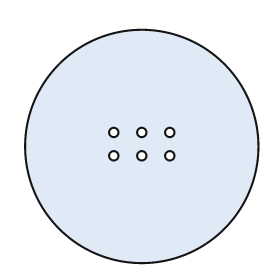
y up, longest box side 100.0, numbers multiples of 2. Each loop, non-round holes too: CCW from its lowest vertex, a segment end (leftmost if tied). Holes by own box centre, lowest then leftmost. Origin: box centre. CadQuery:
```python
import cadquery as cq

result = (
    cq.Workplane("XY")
    .moveTo(0.0, 0.0)
    .circle(50.0)
    .moveTo(-12.0, -4.0)
    .circle(2.0)
    .moveTo(0.0, -4.0)
    .circle(2.0)
    .moveTo(12.0, -4.0)
    .circle(2.0)
    .moveTo(-12.0, 6.0)
    .circle(2.0)
    .moveTo(0.0, 6.0)
    .circle(2.0)
    .moveTo(12.0, 6.0)
    .circle(2.0)
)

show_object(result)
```